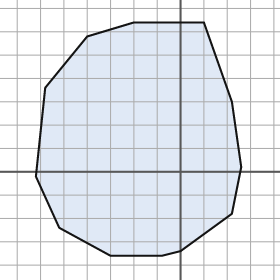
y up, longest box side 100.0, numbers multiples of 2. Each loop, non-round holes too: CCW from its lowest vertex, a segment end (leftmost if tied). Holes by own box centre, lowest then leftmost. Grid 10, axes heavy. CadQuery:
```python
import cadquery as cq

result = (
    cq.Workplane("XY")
    .moveTo(-30.0, -36.0)
    .lineTo(-8.0, -36.0)
    .lineTo(0.0, -34.0)
    .lineTo(22.0, -18.0)
    .lineTo(26.0, 2.0)
    .lineTo(22.0, 30.0)
    .lineTo(10.0, 64.0)
    .lineTo(-20.0, 64.0)
    .lineTo(-40.0, 58.0)
    .lineTo(-58.0, 36.0)
    .lineTo(-62.0, -2.0)
    .lineTo(-52.0, -24.0)
    .close()
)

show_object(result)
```